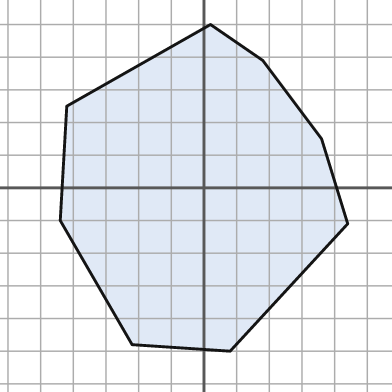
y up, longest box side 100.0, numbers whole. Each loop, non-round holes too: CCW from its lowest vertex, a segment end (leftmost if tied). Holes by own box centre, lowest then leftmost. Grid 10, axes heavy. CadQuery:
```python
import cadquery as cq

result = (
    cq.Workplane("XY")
    .moveTo(8.0, -50.0)
    .lineTo(44.0, -11.0)
    .lineTo(36.0, 15.0)
    .lineTo(18.0, 39.0)
    .lineTo(2.0, 50.0)
    .lineTo(-42.0, 25.0)
    .lineTo(-44.0, -10.0)
    .lineTo(-22.0, -48.0)
    .close()
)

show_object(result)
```